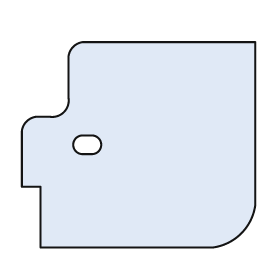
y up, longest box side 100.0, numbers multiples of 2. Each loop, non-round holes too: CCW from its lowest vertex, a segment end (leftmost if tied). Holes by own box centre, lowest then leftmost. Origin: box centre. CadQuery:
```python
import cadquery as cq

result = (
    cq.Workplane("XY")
    .moveTo(-42.0, -44.0)
    .lineTo(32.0, -44.0)
    .threePointArc((44.0, -38.0), (50.0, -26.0))
    .lineTo(50.0, 44.0)
    .lineTo(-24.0, 44.0)
    .threePointArc((-28.0, 42.0), (-30.0, 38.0))
    .lineTo(-30.0, 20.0)
    .threePointArc((-32.0, 14.0), (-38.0, 12.0))
    .lineTo(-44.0, 12.0)
    .threePointArc((-48.0, 10.0), (-50.0, 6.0))
    .lineTo(-50.0, -18.0)
    .lineTo(-42.0, -18.0)
    .close()
    .moveTo(-24.0, -4.0)
    .lineTo(-20.0, -4.0)
    .threePointArc((-16.0, 0.0), (-20.0, 4.0))
    .lineTo(-24.0, 4.0)
    .threePointArc((-28.0, 0.0), (-24.0, -4.0))
    .close()
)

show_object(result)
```